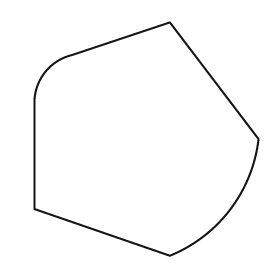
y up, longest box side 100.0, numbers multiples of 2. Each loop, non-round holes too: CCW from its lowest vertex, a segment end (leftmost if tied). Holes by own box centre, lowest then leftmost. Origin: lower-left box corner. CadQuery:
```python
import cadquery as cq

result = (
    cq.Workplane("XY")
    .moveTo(58.0, 0.0)
    .threePointArc((84.0, 20.0), (96.0, 50.0))
    .lineTo(58.0, 100.0)
    .lineTo(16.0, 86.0)
    .threePointArc((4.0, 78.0), (0.0, 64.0))
    .lineTo(0.0, 20.0)
    .close()
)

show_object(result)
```